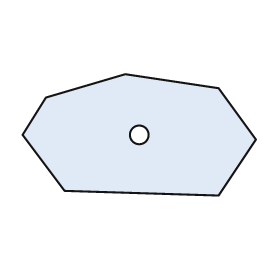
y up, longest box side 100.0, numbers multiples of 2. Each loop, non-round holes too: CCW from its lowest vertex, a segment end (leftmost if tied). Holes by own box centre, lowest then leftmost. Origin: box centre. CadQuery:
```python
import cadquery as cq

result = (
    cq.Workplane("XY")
    .moveTo(34.0, -26.0)
    .lineTo(50.0, -2.0)
    .lineTo(34.0, 20.0)
    .lineTo(-6.0, 26.0)
    .lineTo(-40.0, 16.0)
    .lineTo(-50.0, 0.0)
    .lineTo(-32.0, -24.0)
    .close()
    .moveTo(0.0, 0.0)
    .circle(4.0)
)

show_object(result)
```